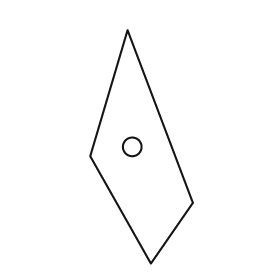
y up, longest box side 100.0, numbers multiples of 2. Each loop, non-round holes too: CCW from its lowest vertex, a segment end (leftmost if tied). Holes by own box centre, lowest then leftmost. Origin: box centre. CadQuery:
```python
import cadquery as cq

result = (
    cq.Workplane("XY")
    .moveTo(4.0, -50.0)
    .lineTo(22.0, -24.0)
    .lineTo(-6.0, 50.0)
    .lineTo(-22.0, -4.0)
    .close()
    .moveTo(-4.0, 0.0)
    .circle(4.0)
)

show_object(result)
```